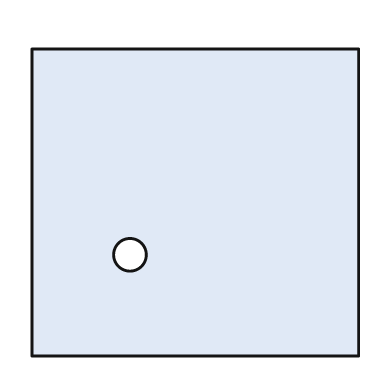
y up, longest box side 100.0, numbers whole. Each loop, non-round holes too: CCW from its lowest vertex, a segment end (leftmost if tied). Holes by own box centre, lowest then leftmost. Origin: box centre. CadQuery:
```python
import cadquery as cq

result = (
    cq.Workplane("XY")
    .moveTo(-50.0, -47.0)
    .lineTo(50.0, -47.0)
    .lineTo(50.0, 47.0)
    .lineTo(-50.0, 47.0)
    .close()
    .moveTo(-20.0, -16.0)
    .circle(5.0)
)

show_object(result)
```